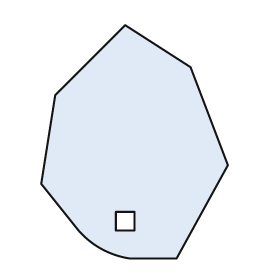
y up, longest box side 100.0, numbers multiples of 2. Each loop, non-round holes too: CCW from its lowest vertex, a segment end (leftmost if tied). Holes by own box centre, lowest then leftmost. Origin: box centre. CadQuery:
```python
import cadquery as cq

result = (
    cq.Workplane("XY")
    .moveTo(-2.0, -50.0)
    .lineTo(18.0, -50.0)
    .lineTo(40.0, -10.0)
    .lineTo(24.0, 32.0)
    .lineTo(-4.0, 50.0)
    .lineTo(-34.0, 20.0)
    .lineTo(-40.0, -18.0)
    .lineTo(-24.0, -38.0)
    .threePointArc((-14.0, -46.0), (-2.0, -50.0))
    .close()
    .moveTo(-8.0, -38.0)
    .lineTo(0.0, -38.0)
    .lineTo(0.0, -30.0)
    .lineTo(-8.0, -30.0)
    .close()
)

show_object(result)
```